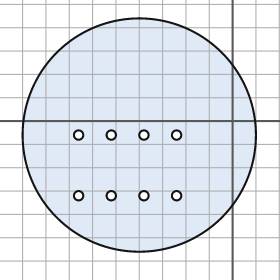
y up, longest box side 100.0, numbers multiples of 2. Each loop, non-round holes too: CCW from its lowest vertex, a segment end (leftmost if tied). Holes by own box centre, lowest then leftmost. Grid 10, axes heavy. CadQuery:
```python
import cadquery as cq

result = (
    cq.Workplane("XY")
    .moveTo(-40.0, -6.0)
    .circle(50.0)
    .moveTo(-66.0, -32.0)
    .circle(2.0)
    .moveTo(-52.0, -32.0)
    .circle(2.0)
    .moveTo(-38.0, -32.0)
    .circle(2.0)
    .moveTo(-24.0, -32.0)
    .circle(2.0)
    .moveTo(-66.0, -6.0)
    .circle(2.0)
    .moveTo(-52.0, -6.0)
    .circle(2.0)
    .moveTo(-38.0, -6.0)
    .circle(2.0)
    .moveTo(-24.0, -6.0)
    .circle(2.0)
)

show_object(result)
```